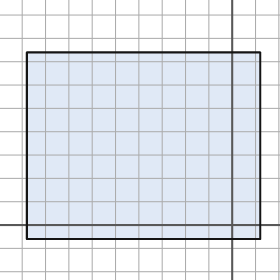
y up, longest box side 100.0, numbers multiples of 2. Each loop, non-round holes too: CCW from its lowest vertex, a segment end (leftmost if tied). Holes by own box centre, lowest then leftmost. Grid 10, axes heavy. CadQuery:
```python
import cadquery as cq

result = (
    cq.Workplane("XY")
    .moveTo(-88.0, -6.0)
    .lineTo(12.0, -6.0)
    .lineTo(12.0, 74.0)
    .lineTo(-88.0, 74.0)
    .close()
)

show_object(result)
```